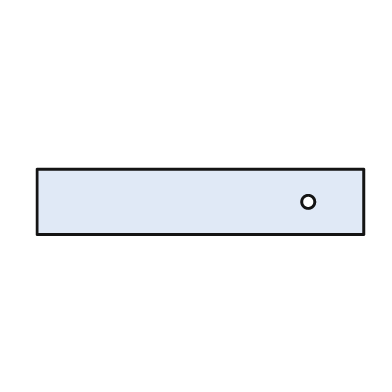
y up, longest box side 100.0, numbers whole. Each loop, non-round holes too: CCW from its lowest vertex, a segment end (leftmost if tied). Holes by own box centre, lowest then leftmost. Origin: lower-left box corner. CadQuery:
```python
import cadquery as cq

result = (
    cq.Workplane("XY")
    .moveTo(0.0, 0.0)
    .lineTo(100.0, 0.0)
    .lineTo(100.0, 20.0)
    .lineTo(0.0, 20.0)
    .close()
    .moveTo(83.0, 10.0)
    .circle(2.0)
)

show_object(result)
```